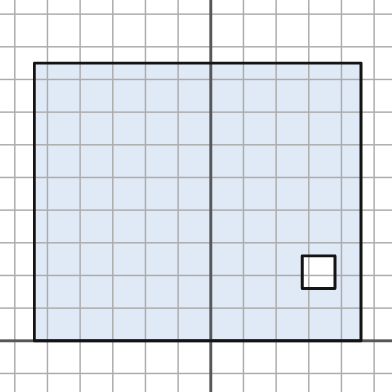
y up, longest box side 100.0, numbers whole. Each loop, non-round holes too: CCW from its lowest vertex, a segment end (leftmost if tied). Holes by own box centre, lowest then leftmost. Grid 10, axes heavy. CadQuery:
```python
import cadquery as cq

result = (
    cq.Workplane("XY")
    .moveTo(-54.0, 0.0)
    .lineTo(46.0, 0.0)
    .lineTo(46.0, 85.0)
    .lineTo(-54.0, 85.0)
    .close()
    .moveTo(28.0, 16.0)
    .lineTo(38.0, 16.0)
    .lineTo(38.0, 26.0)
    .lineTo(28.0, 26.0)
    .close()
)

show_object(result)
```